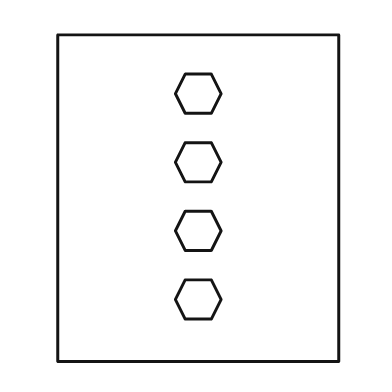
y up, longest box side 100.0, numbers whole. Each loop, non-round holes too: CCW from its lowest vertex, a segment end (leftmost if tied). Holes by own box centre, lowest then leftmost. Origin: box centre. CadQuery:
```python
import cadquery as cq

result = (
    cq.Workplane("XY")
    .moveTo(-43.0, -50.0)
    .lineTo(43.0, -50.0)
    .lineTo(43.0, 50.0)
    .lineTo(-43.0, 50.0)
    .close()
    .moveTo(-4.0, -37.0)
    .lineTo(4.0, -37.0)
    .lineTo(7.0, -31.0)
    .lineTo(4.0, -25.0)
    .lineTo(-4.0, -25.0)
    .lineTo(-7.0, -31.0)
    .close()
    .moveTo(-4.0, -16.0)
    .lineTo(4.0, -16.0)
    .lineTo(7.0, -10.0)
    .lineTo(4.0, -4.0)
    .lineTo(-4.0, -4.0)
    .lineTo(-7.0, -10.0)
    .close()
    .moveTo(-4.0, 5.0)
    .lineTo(4.0, 5.0)
    .lineTo(7.0, 11.0)
    .lineTo(4.0, 17.0)
    .lineTo(-4.0, 17.0)
    .lineTo(-7.0, 11.0)
    .close()
    .moveTo(-4.0, 26.0)
    .lineTo(4.0, 26.0)
    .lineTo(7.0, 32.0)
    .lineTo(4.0, 38.0)
    .lineTo(-4.0, 38.0)
    .lineTo(-7.0, 32.0)
    .close()
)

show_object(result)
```